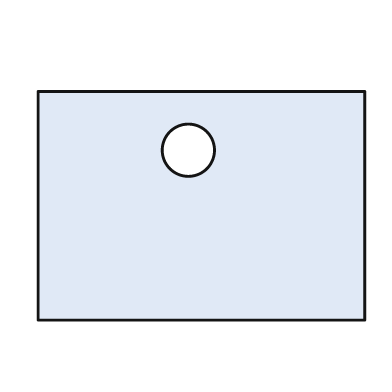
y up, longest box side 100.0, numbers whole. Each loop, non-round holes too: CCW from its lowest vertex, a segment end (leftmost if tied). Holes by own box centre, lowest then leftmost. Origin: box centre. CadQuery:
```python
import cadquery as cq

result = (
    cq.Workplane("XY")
    .moveTo(-50.0, -35.0)
    .lineTo(50.0, -35.0)
    .lineTo(50.0, 35.0)
    .lineTo(-50.0, 35.0)
    .close()
    .moveTo(-4.0, 17.0)
    .circle(8.0)
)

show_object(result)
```